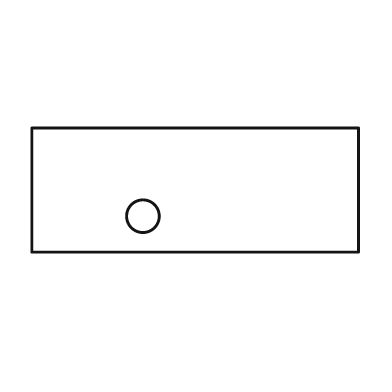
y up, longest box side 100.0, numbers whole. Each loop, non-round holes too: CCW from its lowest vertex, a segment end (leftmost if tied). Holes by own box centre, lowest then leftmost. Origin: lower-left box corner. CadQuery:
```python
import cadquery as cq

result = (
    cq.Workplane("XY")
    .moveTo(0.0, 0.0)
    .lineTo(100.0, 0.0)
    .lineTo(100.0, 38.0)
    .lineTo(0.0, 38.0)
    .close()
    .moveTo(34.0, 11.0)
    .circle(5.0)
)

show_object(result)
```